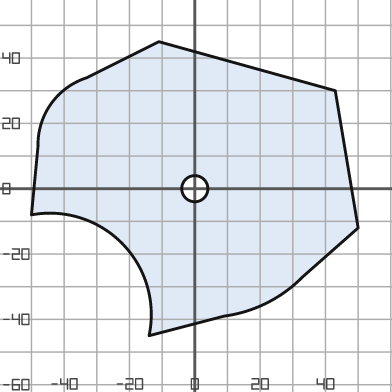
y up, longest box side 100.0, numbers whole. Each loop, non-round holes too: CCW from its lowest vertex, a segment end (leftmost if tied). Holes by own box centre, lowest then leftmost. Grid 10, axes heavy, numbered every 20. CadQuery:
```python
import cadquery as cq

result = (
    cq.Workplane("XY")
    .moveTo(-14.0, -45.0)
    .lineTo(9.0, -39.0)
    .threePointArc((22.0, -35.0), (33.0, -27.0))
    .lineTo(50.0, -12.0)
    .lineTo(43.0, 30.0)
    .lineTo(-11.0, 45.0)
    .lineTo(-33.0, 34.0)
    .threePointArc((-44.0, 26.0), (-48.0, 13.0))
    .lineTo(-50.0, -8.0)
    .threePointArc((-22.0, -17.0), (-14.0, -45.0))
    .close()
    .moveTo(0.0, 0.0)
    .circle(4.0)
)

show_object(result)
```